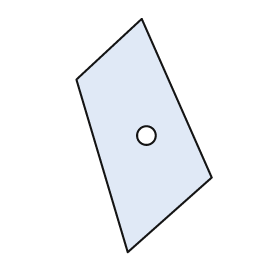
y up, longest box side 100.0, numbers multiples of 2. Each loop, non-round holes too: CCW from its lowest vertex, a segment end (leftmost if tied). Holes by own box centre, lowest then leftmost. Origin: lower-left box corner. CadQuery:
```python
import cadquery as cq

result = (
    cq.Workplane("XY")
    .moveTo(22.0, 0.0)
    .lineTo(58.0, 32.0)
    .lineTo(28.0, 100.0)
    .lineTo(0.0, 74.0)
    .close()
    .moveTo(30.0, 50.0)
    .circle(4.0)
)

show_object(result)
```